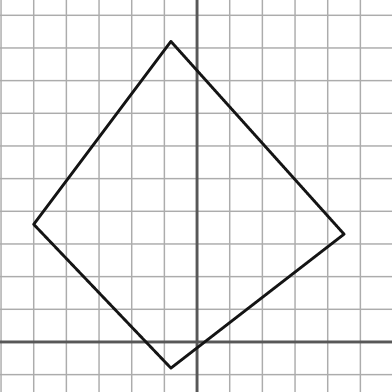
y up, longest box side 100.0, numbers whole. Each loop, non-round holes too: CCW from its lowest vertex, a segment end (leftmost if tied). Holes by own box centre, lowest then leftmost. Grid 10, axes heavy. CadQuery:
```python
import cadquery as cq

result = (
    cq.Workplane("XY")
    .moveTo(-8.0, -8.0)
    .lineTo(45.0, 33.0)
    .lineTo(-8.0, 92.0)
    .lineTo(-50.0, 36.0)
    .close()
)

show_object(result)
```